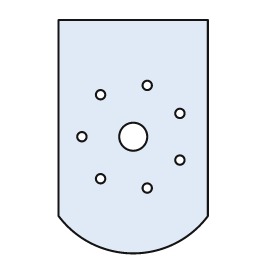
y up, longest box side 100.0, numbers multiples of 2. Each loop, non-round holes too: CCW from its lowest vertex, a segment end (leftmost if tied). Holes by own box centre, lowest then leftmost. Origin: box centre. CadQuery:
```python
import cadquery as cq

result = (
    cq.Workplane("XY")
    .moveTo(-32.0, -34.0)
    .threePointArc((0.0, -50.0), (32.0, -34.0))
    .lineTo(32.0, 50.0)
    .lineTo(-32.0, 50.0)
    .close()
    .moveTo(6.0, -22.0)
    .circle(2.0)
    .moveTo(-14.0, -18.0)
    .circle(2.0)
    .moveTo(20.0, -10.0)
    .circle(2.0)
    .moveTo(-22.0, 0.0)
    .circle(2.0)
    .moveTo(0.0, 0.0)
    .circle(6.0)
    .moveTo(20.0, 10.0)
    .circle(2.0)
    .moveTo(-14.0, 18.0)
    .circle(2.0)
    .moveTo(6.0, 22.0)
    .circle(2.0)
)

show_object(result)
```